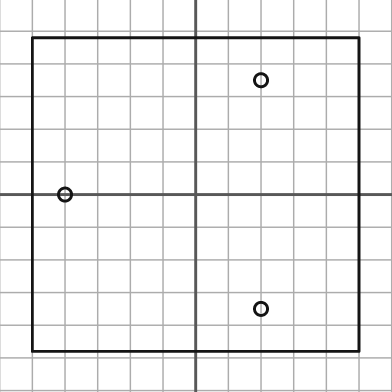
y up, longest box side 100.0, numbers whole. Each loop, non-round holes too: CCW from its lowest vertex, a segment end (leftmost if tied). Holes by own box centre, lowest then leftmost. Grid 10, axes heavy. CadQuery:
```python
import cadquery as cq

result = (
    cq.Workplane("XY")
    .moveTo(-50.0, -48.0)
    .lineTo(50.0, -48.0)
    .lineTo(50.0, 48.0)
    .lineTo(-50.0, 48.0)
    .close()
    .moveTo(20.0, -35.0)
    .circle(2.0)
    .moveTo(-40.0, 0.0)
    .circle(2.0)
    .moveTo(20.0, 35.0)
    .circle(2.0)
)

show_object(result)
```